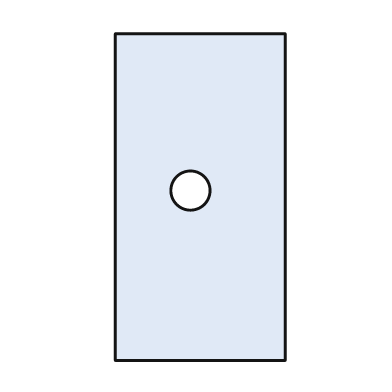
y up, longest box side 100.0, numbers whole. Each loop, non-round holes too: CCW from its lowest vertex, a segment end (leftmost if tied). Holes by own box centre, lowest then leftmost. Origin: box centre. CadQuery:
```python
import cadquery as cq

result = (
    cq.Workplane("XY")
    .moveTo(-26.0, -50.0)
    .lineTo(26.0, -50.0)
    .lineTo(26.0, 50.0)
    .lineTo(-26.0, 50.0)
    .close()
    .moveTo(-3.0, 2.0)
    .circle(6.0)
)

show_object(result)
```